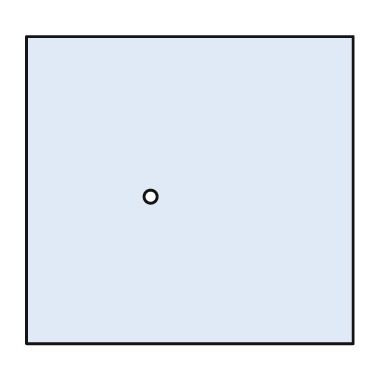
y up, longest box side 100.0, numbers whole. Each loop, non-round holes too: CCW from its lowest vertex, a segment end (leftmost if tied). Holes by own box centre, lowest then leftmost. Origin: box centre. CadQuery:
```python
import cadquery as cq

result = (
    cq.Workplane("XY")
    .moveTo(-50.0, -47.0)
    .lineTo(50.0, -47.0)
    .lineTo(50.0, 47.0)
    .lineTo(-50.0, 47.0)
    .close()
    .moveTo(-12.0, -2.0)
    .circle(2.0)
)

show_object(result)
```